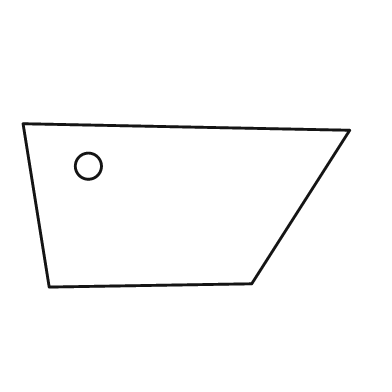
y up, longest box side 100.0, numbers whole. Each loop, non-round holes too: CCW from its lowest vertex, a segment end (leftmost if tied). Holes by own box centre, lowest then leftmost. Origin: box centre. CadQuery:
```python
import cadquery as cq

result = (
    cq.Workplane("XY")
    .moveTo(-42.0, -25.0)
    .lineTo(20.0, -24.0)
    .lineTo(50.0, 23.0)
    .lineTo(-50.0, 25.0)
    .close()
    .moveTo(-30.0, 12.0)
    .circle(4.0)
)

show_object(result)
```